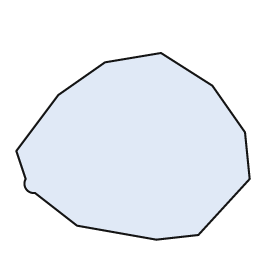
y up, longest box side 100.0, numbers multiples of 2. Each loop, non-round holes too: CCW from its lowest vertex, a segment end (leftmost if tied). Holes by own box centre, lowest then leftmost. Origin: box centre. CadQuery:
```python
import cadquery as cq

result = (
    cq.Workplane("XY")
    .moveTo(10.0, -40.0)
    .lineTo(28.0, -38.0)
    .lineTo(50.0, -14.0)
    .lineTo(48.0, 6.0)
    .lineTo(34.0, 26.0)
    .lineTo(12.0, 40.0)
    .lineTo(-12.0, 36.0)
    .lineTo(-32.0, 22.0)
    .lineTo(-50.0, -2.0)
    .lineTo(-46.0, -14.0)
    .threePointArc((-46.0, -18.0), (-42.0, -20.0))
    .lineTo(-24.0, -34.0)
    .close()
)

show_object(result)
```